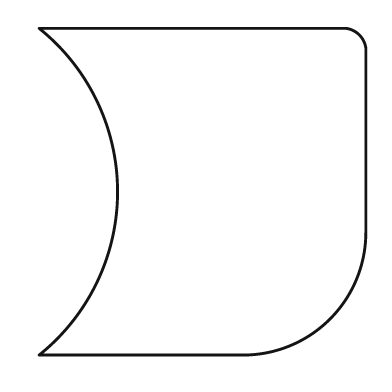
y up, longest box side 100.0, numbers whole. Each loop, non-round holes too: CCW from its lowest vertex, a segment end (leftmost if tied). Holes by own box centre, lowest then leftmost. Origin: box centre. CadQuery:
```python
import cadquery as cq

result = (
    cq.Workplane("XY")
    .moveTo(-50.0, -50.0)
    .lineTo(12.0, -50.0)
    .threePointArc((39.0, -39.0), (50.0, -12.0))
    .lineTo(50.0, 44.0)
    .threePointArc((48.0, 48.0), (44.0, 50.0))
    .lineTo(-50.0, 50.0)
    .threePointArc((-26.0, 0.0), (-50.0, -50.0))
    .close()
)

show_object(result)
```